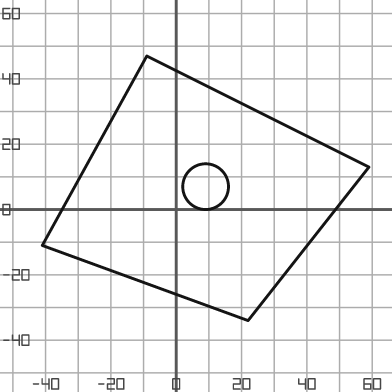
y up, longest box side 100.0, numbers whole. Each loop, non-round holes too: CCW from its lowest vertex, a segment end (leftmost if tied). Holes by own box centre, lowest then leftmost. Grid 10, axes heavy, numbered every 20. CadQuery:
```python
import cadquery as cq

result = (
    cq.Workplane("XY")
    .moveTo(22.0, -34.0)
    .lineTo(59.0, 13.0)
    .lineTo(-9.0, 47.0)
    .lineTo(-41.0, -11.0)
    .close()
    .moveTo(9.0, 7.0)
    .circle(7.0)
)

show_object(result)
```